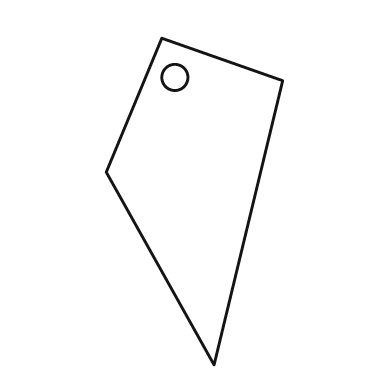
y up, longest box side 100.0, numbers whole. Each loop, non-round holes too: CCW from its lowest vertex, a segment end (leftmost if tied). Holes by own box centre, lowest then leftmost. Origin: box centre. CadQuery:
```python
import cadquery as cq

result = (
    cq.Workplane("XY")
    .moveTo(6.0, -50.0)
    .lineTo(27.0, 37.0)
    .lineTo(-10.0, 50.0)
    .lineTo(-27.0, 9.0)
    .close()
    .moveTo(-6.0, 38.0)
    .circle(4.0)
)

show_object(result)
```